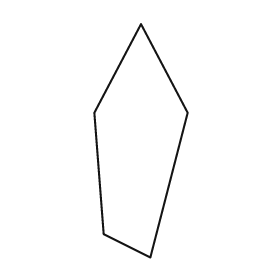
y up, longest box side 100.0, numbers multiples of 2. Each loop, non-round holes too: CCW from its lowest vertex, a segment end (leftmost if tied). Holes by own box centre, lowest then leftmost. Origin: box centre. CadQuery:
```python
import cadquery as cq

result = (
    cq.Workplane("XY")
    .moveTo(4.0, -50.0)
    .lineTo(20.0, 12.0)
    .lineTo(0.0, 50.0)
    .lineTo(-20.0, 12.0)
    .lineTo(-16.0, -40.0)
    .close()
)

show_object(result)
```